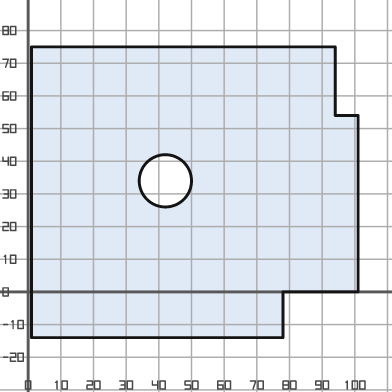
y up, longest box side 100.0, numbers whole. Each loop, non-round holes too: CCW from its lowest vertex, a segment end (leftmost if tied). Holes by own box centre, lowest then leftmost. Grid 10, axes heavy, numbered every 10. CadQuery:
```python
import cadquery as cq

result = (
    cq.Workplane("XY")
    .moveTo(1.0, -14.0)
    .lineTo(78.0, -14.0)
    .lineTo(78.0, 0.0)
    .lineTo(101.0, 0.0)
    .lineTo(101.0, 54.0)
    .lineTo(94.0, 54.0)
    .lineTo(94.0, 75.0)
    .lineTo(1.0, 75.0)
    .close()
    .moveTo(42.0, 34.0)
    .circle(8.0)
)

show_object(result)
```